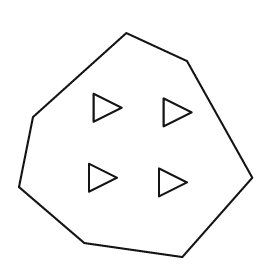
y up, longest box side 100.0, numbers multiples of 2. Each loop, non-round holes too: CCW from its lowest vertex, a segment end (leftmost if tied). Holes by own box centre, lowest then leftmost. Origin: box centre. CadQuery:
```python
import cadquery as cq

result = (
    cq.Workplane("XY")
    .moveTo(20.0, -48.0)
    .lineTo(50.0, -14.0)
    .lineTo(22.0, 36.0)
    .lineTo(-4.0, 48.0)
    .lineTo(-44.0, 12.0)
    .lineTo(-50.0, -18.0)
    .lineTo(-22.0, -42.0)
    .close()
    .moveTo(10.0, -22.0)
    .lineTo(22.0, -16.0)
    .lineTo(10.0, -10.0)
    .close()
    .moveTo(-20.0, -20.0)
    .lineTo(-8.0, -14.0)
    .lineTo(-20.0, -8.0)
    .close()
    .moveTo(12.0, 8.0)
    .lineTo(24.0, 14.0)
    .lineTo(12.0, 20.0)
    .close()
    .moveTo(-18.0, 10.0)
    .lineTo(-6.0, 16.0)
    .lineTo(-18.0, 22.0)
    .close()
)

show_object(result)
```